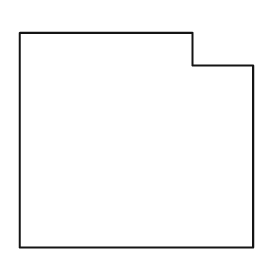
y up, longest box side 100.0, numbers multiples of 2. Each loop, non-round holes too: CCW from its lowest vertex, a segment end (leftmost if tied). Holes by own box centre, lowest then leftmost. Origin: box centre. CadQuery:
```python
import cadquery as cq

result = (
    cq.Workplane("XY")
    .moveTo(-50.0, -46.0)
    .lineTo(50.0, -46.0)
    .lineTo(50.0, 32.0)
    .lineTo(24.0, 32.0)
    .lineTo(24.0, 46.0)
    .lineTo(-50.0, 46.0)
    .close()
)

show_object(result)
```